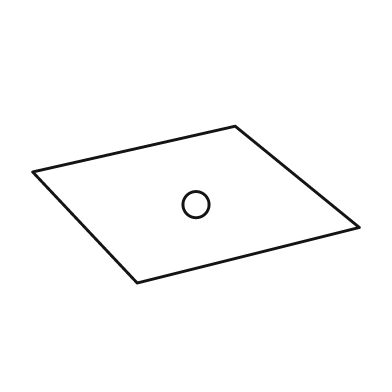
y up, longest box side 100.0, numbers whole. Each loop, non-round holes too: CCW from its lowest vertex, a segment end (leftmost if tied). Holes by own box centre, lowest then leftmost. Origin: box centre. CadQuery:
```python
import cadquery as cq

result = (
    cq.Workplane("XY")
    .moveTo(-18.0, -24.0)
    .lineTo(50.0, -7.0)
    .lineTo(12.0, 24.0)
    .lineTo(-50.0, 10.0)
    .close()
    .moveTo(0.0, 0.0)
    .circle(4.0)
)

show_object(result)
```